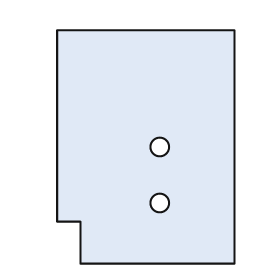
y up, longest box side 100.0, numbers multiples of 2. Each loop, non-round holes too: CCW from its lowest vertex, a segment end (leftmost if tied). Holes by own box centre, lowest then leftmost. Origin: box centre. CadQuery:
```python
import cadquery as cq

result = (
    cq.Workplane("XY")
    .moveTo(-28.0, -50.0)
    .lineTo(38.0, -50.0)
    .lineTo(38.0, 50.0)
    .lineTo(-38.0, 50.0)
    .lineTo(-38.0, -32.0)
    .lineTo(-28.0, -32.0)
    .close()
    .moveTo(6.0, -24.0)
    .circle(4.0)
    .moveTo(6.0, 0.0)
    .circle(4.0)
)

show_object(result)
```